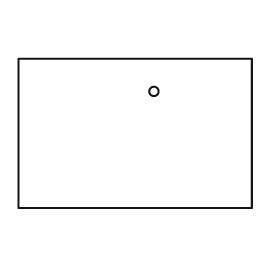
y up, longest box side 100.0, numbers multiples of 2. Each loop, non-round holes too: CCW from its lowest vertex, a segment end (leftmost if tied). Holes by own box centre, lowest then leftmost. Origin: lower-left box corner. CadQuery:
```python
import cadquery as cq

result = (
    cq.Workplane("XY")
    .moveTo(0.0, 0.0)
    .lineTo(100.0, 0.0)
    .lineTo(100.0, 64.0)
    .lineTo(0.0, 64.0)
    .close()
    .moveTo(58.0, 50.0)
    .circle(2.0)
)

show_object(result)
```